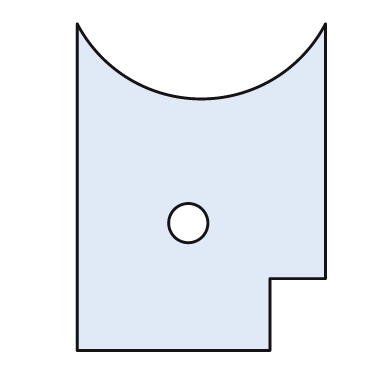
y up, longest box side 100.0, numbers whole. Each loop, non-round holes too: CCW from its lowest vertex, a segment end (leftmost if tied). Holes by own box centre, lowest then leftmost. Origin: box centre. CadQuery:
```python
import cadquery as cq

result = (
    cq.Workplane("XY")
    .moveTo(-38.0, -50.0)
    .lineTo(21.0, -50.0)
    .lineTo(21.0, -28.0)
    .lineTo(38.0, -28.0)
    .lineTo(38.0, 50.0)
    .threePointArc((0.0, 27.0), (-38.0, 50.0))
    .close()
    .moveTo(-4.0, -11.0)
    .circle(6.0)
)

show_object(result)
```